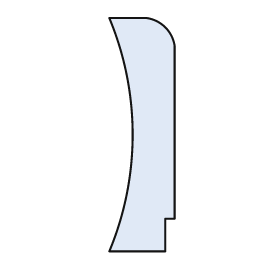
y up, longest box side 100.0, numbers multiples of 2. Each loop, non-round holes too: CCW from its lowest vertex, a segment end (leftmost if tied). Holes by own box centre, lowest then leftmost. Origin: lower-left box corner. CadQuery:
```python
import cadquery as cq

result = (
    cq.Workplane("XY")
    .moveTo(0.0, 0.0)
    .lineTo(24.0, 0.0)
    .lineTo(24.0, 14.0)
    .lineTo(28.0, 14.0)
    .lineTo(28.0, 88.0)
    .threePointArc((24.0, 96.0), (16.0, 100.0))
    .lineTo(0.0, 100.0)
    .threePointArc((10.0, 50.0), (0.0, 0.0))
    .close()
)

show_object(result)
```